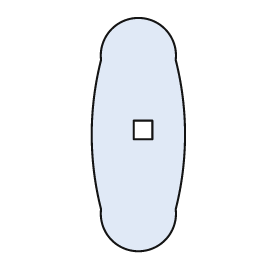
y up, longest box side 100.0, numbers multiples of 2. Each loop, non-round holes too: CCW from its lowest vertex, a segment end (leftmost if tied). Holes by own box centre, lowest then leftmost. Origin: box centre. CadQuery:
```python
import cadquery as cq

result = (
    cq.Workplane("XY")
    .moveTo(-16.0, -32.0)
    .threePointArc((0.0, -50.0), (16.0, -32.0))
    .threePointArc((20.0, 0.0), (16.0, 32.0))
    .threePointArc((0.0, 50.0), (-16.0, 32.0))
    .threePointArc((-20.0, 0.0), (-16.0, -32.0))
    .close()
    .moveTo(-2.0, -2.0)
    .lineTo(6.0, -2.0)
    .lineTo(6.0, 6.0)
    .lineTo(-2.0, 6.0)
    .close()
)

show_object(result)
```